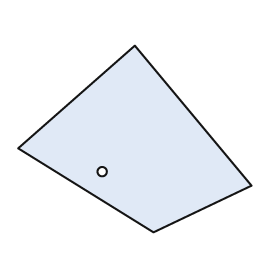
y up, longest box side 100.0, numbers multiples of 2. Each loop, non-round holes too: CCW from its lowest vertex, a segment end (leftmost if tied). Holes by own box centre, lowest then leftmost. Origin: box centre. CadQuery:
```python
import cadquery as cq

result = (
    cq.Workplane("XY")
    .moveTo(8.0, -40.0)
    .lineTo(50.0, -20.0)
    .lineTo(0.0, 40.0)
    .lineTo(-50.0, -4.0)
    .close()
    .moveTo(-14.0, -14.0)
    .circle(2.0)
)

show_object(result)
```